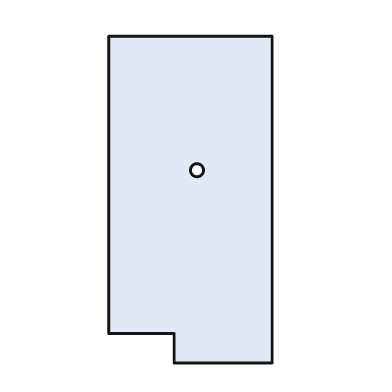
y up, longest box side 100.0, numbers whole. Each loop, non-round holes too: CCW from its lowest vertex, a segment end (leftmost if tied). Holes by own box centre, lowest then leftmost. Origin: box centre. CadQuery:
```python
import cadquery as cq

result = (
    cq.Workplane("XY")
    .moveTo(-5.0, -50.0)
    .lineTo(25.0, -50.0)
    .lineTo(25.0, 50.0)
    .lineTo(-25.0, 50.0)
    .lineTo(-25.0, -41.0)
    .lineTo(-5.0, -41.0)
    .close()
    .moveTo(2.0, 9.0)
    .circle(2.0)
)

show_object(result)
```